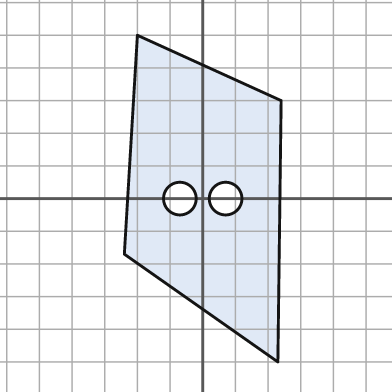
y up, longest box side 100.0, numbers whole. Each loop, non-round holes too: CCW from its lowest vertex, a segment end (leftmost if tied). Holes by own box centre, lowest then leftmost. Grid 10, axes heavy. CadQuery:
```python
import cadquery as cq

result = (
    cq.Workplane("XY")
    .moveTo(23.0, -50.0)
    .lineTo(24.0, 30.0)
    .lineTo(-20.0, 50.0)
    .lineTo(-24.0, -17.0)
    .close()
    .moveTo(-7.0, 0.0)
    .circle(5.0)
    .moveTo(7.0, 0.0)
    .circle(5.0)
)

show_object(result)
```